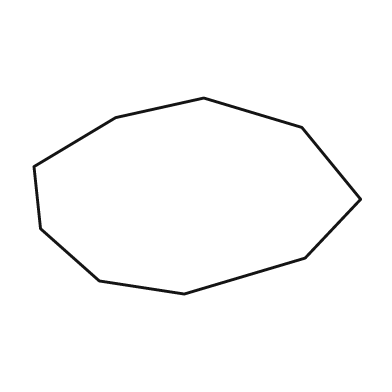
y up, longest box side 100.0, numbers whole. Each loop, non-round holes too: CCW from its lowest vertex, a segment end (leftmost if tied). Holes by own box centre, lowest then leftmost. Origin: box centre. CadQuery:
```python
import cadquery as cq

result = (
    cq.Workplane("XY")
    .moveTo(-4.0, -30.0)
    .lineTo(33.0, -19.0)
    .lineTo(50.0, -1.0)
    .lineTo(32.0, 21.0)
    .lineTo(2.0, 30.0)
    .lineTo(-25.0, 24.0)
    .lineTo(-50.0, 9.0)
    .lineTo(-48.0, -10.0)
    .lineTo(-30.0, -26.0)
    .close()
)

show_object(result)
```